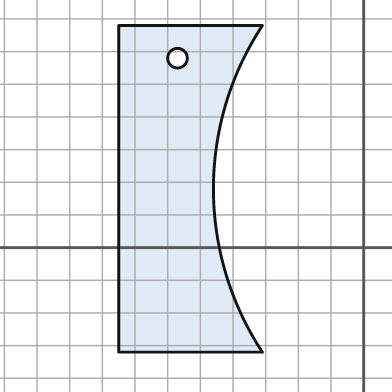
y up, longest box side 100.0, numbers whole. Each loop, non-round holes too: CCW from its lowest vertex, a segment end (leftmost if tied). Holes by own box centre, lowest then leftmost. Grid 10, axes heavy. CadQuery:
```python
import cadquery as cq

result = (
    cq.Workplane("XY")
    .moveTo(-75.0, -32.0)
    .lineTo(-31.0, -32.0)
    .threePointArc((-46.0, 18.0), (-31.0, 68.0))
    .lineTo(-75.0, 68.0)
    .close()
    .moveTo(-57.0, 58.0)
    .circle(3.0)
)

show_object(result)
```